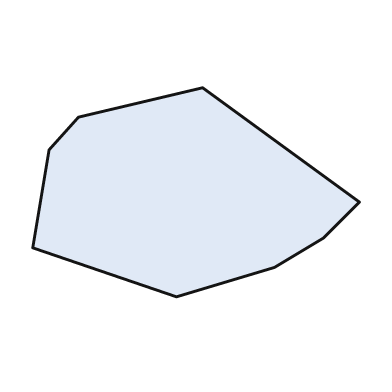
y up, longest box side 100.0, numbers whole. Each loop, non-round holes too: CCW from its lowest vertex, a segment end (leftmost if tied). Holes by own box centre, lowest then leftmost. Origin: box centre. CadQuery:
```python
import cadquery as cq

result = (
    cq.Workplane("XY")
    .moveTo(-6.0, -32.0)
    .lineTo(24.0, -23.0)
    .lineTo(39.0, -14.0)
    .lineTo(50.0, -3.0)
    .lineTo(2.0, 32.0)
    .lineTo(-36.0, 23.0)
    .lineTo(-45.0, 13.0)
    .lineTo(-50.0, -17.0)
    .close()
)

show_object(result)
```